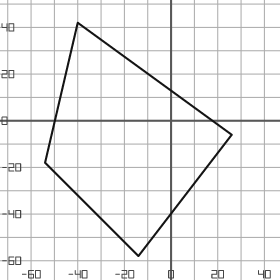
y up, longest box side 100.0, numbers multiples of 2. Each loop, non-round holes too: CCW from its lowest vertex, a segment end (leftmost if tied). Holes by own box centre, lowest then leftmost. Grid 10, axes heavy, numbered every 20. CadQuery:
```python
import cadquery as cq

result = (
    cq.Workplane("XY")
    .moveTo(-14.0, -58.0)
    .lineTo(26.0, -6.0)
    .lineTo(-40.0, 42.0)
    .lineTo(-54.0, -18.0)
    .close()
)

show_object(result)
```